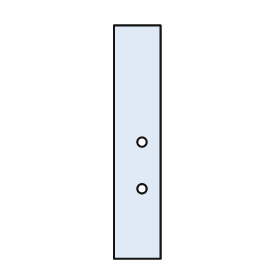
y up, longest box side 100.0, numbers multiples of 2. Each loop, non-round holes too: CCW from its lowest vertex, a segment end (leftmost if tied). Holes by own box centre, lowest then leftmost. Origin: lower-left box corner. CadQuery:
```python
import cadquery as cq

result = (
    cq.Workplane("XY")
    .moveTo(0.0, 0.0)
    .lineTo(20.0, 0.0)
    .lineTo(20.0, 100.0)
    .lineTo(0.0, 100.0)
    .close()
    .moveTo(12.0, 30.0)
    .circle(2.0)
    .moveTo(12.0, 50.0)
    .circle(2.0)
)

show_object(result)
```